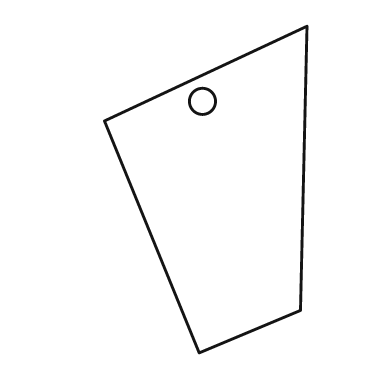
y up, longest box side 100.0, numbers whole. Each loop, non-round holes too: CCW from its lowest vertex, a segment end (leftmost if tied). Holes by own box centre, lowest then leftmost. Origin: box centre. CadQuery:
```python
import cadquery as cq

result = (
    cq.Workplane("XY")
    .moveTo(-2.0, -50.0)
    .lineTo(29.0, -37.0)
    .lineTo(31.0, 50.0)
    .lineTo(-31.0, 21.0)
    .close()
    .moveTo(-1.0, 27.0)
    .circle(4.0)
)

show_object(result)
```